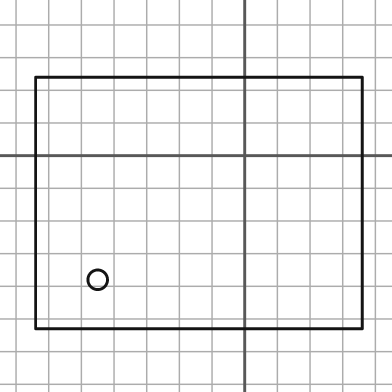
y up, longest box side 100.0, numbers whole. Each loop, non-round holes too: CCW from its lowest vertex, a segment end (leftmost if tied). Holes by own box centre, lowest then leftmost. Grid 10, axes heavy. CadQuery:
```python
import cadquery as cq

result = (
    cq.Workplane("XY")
    .moveTo(-64.0, -53.0)
    .lineTo(36.0, -53.0)
    .lineTo(36.0, 24.0)
    .lineTo(-64.0, 24.0)
    .close()
    .moveTo(-45.0, -38.0)
    .circle(3.0)
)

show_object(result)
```